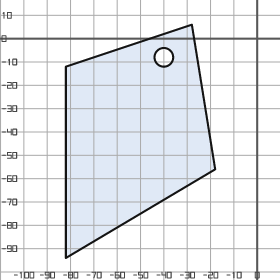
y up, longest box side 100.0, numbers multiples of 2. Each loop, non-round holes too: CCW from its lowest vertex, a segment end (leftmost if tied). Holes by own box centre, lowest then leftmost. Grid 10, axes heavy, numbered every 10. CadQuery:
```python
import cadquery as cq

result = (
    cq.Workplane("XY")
    .moveTo(-82.0, -94.0)
    .lineTo(-18.0, -56.0)
    .lineTo(-28.0, 6.0)
    .lineTo(-82.0, -12.0)
    .close()
    .moveTo(-40.0, -8.0)
    .circle(4.0)
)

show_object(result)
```